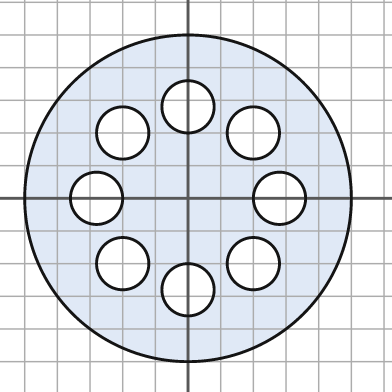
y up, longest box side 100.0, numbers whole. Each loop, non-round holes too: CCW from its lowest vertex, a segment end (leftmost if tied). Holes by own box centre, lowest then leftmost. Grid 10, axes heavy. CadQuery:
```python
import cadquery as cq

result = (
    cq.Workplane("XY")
    .moveTo(0.0, 0.0)
    .circle(50.0)
    .moveTo(0.0, -28.0)
    .circle(8.0)
    .moveTo(-20.0, -20.0)
    .circle(8.0)
    .moveTo(20.0, -20.0)
    .circle(8.0)
    .moveTo(-28.0, 0.0)
    .circle(8.0)
    .moveTo(28.0, 0.0)
    .circle(8.0)
    .moveTo(-20.0, 20.0)
    .circle(8.0)
    .moveTo(20.0, 20.0)
    .circle(8.0)
    .moveTo(0.0, 28.0)
    .circle(8.0)
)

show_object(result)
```